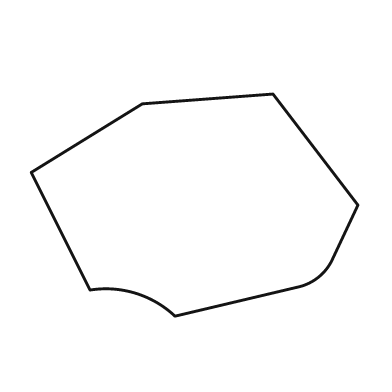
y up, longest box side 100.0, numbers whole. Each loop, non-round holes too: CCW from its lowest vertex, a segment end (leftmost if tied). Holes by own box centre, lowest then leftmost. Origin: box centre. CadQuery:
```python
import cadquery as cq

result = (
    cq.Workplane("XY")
    .moveTo(-6.0, -34.0)
    .lineTo(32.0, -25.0)
    .threePointArc((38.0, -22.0), (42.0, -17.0))
    .lineTo(50.0, 0.0)
    .lineTo(24.0, 34.0)
    .lineTo(-16.0, 31.0)
    .lineTo(-50.0, 10.0)
    .lineTo(-32.0, -26.0)
    .threePointArc((-18.0, -27.0), (-6.0, -34.0))
    .close()
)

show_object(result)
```